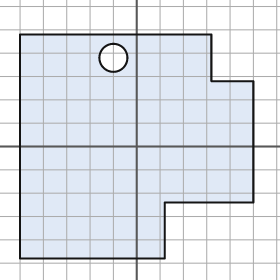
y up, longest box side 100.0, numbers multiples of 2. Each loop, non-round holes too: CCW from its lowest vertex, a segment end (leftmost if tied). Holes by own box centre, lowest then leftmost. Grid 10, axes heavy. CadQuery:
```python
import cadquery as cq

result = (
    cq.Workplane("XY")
    .moveTo(-50.0, -48.0)
    .lineTo(12.0, -48.0)
    .lineTo(12.0, -24.0)
    .lineTo(50.0, -24.0)
    .lineTo(50.0, 28.0)
    .lineTo(32.0, 28.0)
    .lineTo(32.0, 48.0)
    .lineTo(-50.0, 48.0)
    .close()
    .moveTo(-10.0, 38.0)
    .circle(6.0)
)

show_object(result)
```